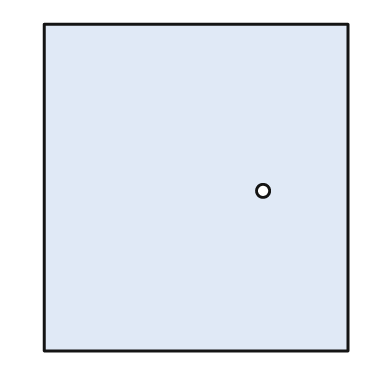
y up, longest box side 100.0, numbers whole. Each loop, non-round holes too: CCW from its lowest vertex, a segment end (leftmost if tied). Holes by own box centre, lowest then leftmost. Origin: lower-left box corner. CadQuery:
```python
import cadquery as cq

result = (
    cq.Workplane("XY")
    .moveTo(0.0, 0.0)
    .lineTo(93.0, 0.0)
    .lineTo(93.0, 100.0)
    .lineTo(0.0, 100.0)
    .close()
    .moveTo(67.0, 49.0)
    .circle(2.0)
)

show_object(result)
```